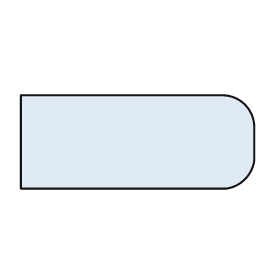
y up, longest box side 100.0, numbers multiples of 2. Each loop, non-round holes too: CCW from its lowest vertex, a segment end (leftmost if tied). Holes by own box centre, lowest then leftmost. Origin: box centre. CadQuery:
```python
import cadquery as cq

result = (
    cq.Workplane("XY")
    .moveTo(-50.0, -20.0)
    .lineTo(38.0, -20.0)
    .threePointArc((46.0, -16.0), (50.0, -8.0))
    .lineTo(50.0, 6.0)
    .threePointArc((46.0, 16.0), (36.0, 20.0))
    .lineTo(-50.0, 20.0)
    .close()
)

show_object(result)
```